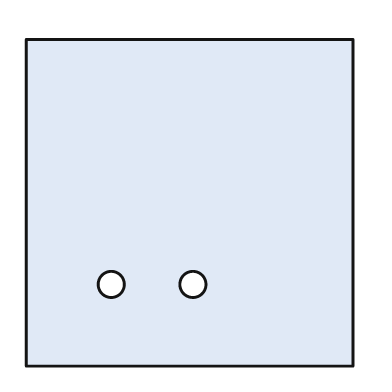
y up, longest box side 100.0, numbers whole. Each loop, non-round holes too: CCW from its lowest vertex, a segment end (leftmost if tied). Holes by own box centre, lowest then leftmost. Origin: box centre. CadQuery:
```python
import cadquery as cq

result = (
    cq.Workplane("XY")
    .moveTo(-50.0, -50.0)
    .lineTo(50.0, -50.0)
    .lineTo(50.0, 50.0)
    .lineTo(-50.0, 50.0)
    .close()
    .moveTo(-24.0, -25.0)
    .circle(4.0)
    .moveTo(1.0, -25.0)
    .circle(4.0)
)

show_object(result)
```